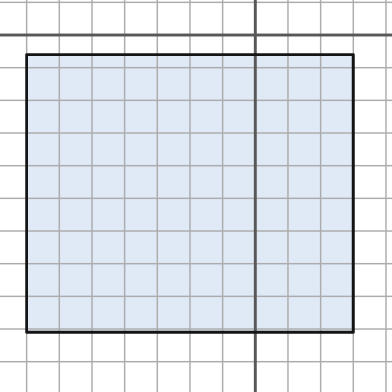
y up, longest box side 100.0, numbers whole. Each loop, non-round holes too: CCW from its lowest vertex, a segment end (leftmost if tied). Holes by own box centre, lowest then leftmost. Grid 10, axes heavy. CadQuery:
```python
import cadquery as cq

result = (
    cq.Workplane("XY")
    .moveTo(-70.0, -91.0)
    .lineTo(30.0, -91.0)
    .lineTo(30.0, -6.0)
    .lineTo(-70.0, -6.0)
    .close()
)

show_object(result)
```